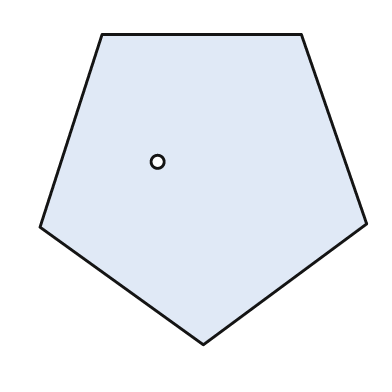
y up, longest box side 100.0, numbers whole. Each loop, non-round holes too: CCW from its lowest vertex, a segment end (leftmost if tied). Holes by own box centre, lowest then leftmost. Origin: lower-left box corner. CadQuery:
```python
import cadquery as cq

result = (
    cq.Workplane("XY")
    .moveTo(50.0, 0.0)
    .lineTo(100.0, 37.0)
    .lineTo(80.0, 95.0)
    .lineTo(19.0, 95.0)
    .lineTo(0.0, 36.0)
    .close()
    .moveTo(36.0, 56.0)
    .circle(2.0)
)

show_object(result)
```